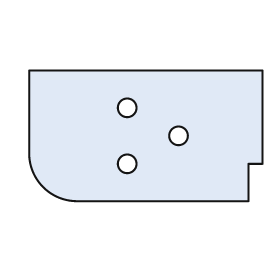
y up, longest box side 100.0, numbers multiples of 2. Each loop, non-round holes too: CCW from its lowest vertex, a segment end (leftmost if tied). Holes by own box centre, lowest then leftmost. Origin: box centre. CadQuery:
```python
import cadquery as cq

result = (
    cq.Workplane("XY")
    .moveTo(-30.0, -28.0)
    .lineTo(44.0, -28.0)
    .lineTo(44.0, -12.0)
    .lineTo(50.0, -12.0)
    .lineTo(50.0, 28.0)
    .lineTo(-50.0, 28.0)
    .lineTo(-50.0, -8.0)
    .threePointArc((-44.0, -22.0), (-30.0, -28.0))
    .close()
    .moveTo(-8.0, -12.0)
    .circle(4.0)
    .moveTo(14.0, 0.0)
    .circle(4.0)
    .moveTo(-8.0, 12.0)
    .circle(4.0)
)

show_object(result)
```